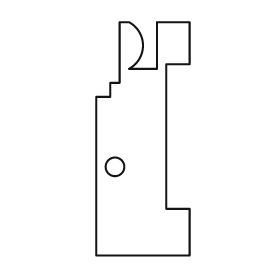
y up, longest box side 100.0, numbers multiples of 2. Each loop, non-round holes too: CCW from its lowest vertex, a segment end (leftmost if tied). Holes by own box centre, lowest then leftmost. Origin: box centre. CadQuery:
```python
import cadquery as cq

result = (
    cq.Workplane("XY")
    .moveTo(-20.0, -50.0)
    .lineTo(20.0, -50.0)
    .lineTo(20.0, -30.0)
    .lineTo(10.0, -30.0)
    .lineTo(10.0, 32.0)
    .lineTo(20.0, 32.0)
    .lineTo(20.0, 50.0)
    .lineTo(6.0, 50.0)
    .lineTo(6.0, 30.0)
    .lineTo(-6.0, 30.0)
    .threePointArc((0.0, 40.0), (-6.0, 50.0))
    .lineTo(-10.0, 50.0)
    .lineTo(-10.0, 24.0)
    .lineTo(-14.0, 24.0)
    .lineTo(-14.0, 18.0)
    .lineTo(-20.0, 18.0)
    .close()
    .moveTo(-12.0, -12.0)
    .circle(4.0)
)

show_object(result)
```